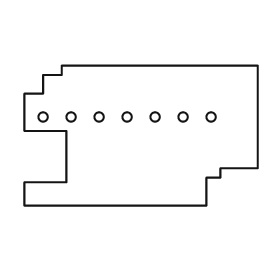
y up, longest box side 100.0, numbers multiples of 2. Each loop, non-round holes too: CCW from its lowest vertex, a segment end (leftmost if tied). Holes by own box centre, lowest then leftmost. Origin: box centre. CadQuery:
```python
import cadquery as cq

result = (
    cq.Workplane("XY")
    .moveTo(-50.0, -30.0)
    .lineTo(28.0, -30.0)
    .lineTo(28.0, -18.0)
    .lineTo(34.0, -18.0)
    .lineTo(34.0, -14.0)
    .lineTo(50.0, -14.0)
    .lineTo(50.0, 30.0)
    .lineTo(-34.0, 30.0)
    .lineTo(-34.0, 26.0)
    .lineTo(-42.0, 26.0)
    .lineTo(-42.0, 18.0)
    .lineTo(-50.0, 18.0)
    .lineTo(-50.0, 2.0)
    .lineTo(-32.0, 2.0)
    .lineTo(-32.0, -20.0)
    .lineTo(-50.0, -20.0)
    .close()
    .moveTo(-42.0, 8.0)
    .circle(2.0)
    .moveTo(-30.0, 8.0)
    .circle(2.0)
    .moveTo(-18.0, 8.0)
    .circle(2.0)
    .moveTo(-6.0, 8.0)
    .circle(2.0)
    .moveTo(6.0, 8.0)
    .circle(2.0)
    .moveTo(18.0, 8.0)
    .circle(2.0)
    .moveTo(30.0, 8.0)
    .circle(2.0)
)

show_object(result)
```